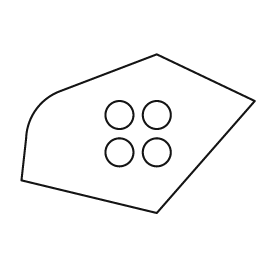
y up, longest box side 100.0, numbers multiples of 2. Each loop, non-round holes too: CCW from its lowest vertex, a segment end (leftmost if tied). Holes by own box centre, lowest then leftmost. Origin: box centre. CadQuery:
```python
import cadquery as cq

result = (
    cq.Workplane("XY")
    .moveTo(8.0, -34.0)
    .lineTo(50.0, 14.0)
    .lineTo(8.0, 34.0)
    .lineTo(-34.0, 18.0)
    .threePointArc((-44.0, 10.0), (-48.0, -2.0))
    .lineTo(-50.0, -20.0)
    .close()
    .moveTo(-8.0, -8.0)
    .circle(6.0)
    .moveTo(8.0, -8.0)
    .circle(6.0)
    .moveTo(-8.0, 8.0)
    .circle(6.0)
    .moveTo(8.0, 8.0)
    .circle(6.0)
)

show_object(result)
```